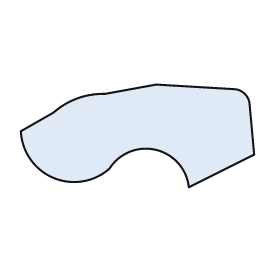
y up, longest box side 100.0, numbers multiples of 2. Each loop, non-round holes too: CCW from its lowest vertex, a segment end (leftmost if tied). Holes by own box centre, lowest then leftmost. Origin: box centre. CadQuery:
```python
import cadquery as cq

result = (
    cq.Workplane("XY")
    .moveTo(22.0, -22.0)
    .lineTo(50.0, -8.0)
    .lineTo(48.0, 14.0)
    .threePointArc((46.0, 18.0), (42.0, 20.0))
    .lineTo(8.0, 22.0)
    .lineTo(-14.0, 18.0)
    .threePointArc((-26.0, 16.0), (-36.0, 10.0))
    .lineTo(-50.0, 2.0)
    .threePointArc((-36.0, -18.0), (-12.0, -14.0))
    .threePointArc((8.0, -6.0), (22.0, -22.0))
    .close()
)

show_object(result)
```